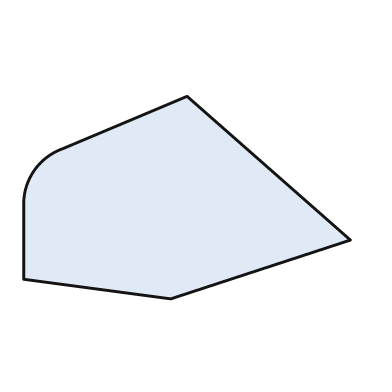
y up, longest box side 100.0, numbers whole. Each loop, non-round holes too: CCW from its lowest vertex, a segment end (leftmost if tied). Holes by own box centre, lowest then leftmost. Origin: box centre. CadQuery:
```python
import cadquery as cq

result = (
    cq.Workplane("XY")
    .moveTo(-5.0, -31.0)
    .lineTo(50.0, -13.0)
    .lineTo(0.0, 31.0)
    .lineTo(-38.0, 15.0)
    .threePointArc((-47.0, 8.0), (-50.0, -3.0))
    .lineTo(-50.0, -25.0)
    .close()
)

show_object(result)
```